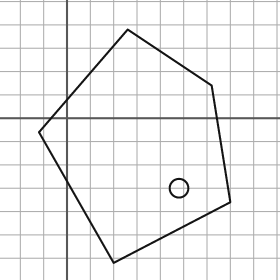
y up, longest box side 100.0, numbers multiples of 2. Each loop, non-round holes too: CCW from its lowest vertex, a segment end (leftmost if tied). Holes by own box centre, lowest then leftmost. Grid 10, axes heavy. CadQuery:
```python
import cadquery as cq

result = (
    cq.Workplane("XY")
    .moveTo(20.0, -62.0)
    .lineTo(70.0, -36.0)
    .lineTo(62.0, 14.0)
    .lineTo(26.0, 38.0)
    .lineTo(-12.0, -6.0)
    .close()
    .moveTo(48.0, -30.0)
    .circle(4.0)
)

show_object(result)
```